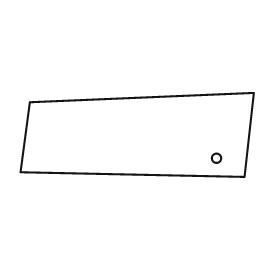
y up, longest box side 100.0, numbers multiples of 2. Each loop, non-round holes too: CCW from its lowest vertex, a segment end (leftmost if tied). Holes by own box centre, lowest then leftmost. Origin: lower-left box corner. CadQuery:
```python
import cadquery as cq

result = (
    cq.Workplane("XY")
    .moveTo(96.0, 0.0)
    .lineTo(100.0, 36.0)
    .lineTo(4.0, 32.0)
    .lineTo(0.0, 2.0)
    .close()
    .moveTo(84.0, 8.0)
    .circle(2.0)
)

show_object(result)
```